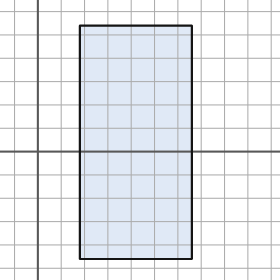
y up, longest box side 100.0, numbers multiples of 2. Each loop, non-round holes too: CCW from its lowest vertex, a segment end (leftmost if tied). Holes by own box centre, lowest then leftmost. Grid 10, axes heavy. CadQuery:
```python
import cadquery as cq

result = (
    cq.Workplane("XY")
    .moveTo(18.0, -46.0)
    .lineTo(66.0, -46.0)
    .lineTo(66.0, 54.0)
    .lineTo(18.0, 54.0)
    .close()
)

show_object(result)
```